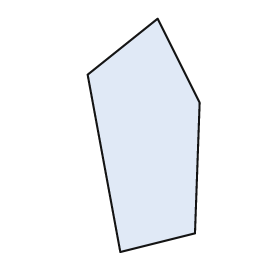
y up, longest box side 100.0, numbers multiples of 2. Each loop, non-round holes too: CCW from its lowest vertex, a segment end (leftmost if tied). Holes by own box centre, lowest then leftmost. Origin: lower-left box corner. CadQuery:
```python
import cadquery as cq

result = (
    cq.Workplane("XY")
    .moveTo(14.0, 0.0)
    .lineTo(46.0, 8.0)
    .lineTo(48.0, 64.0)
    .lineTo(30.0, 100.0)
    .lineTo(0.0, 76.0)
    .close()
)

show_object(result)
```